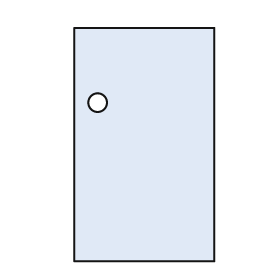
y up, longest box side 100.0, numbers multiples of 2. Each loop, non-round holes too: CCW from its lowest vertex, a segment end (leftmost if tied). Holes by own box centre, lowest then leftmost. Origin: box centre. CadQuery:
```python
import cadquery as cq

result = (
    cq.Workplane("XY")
    .moveTo(-30.0, -50.0)
    .lineTo(30.0, -50.0)
    .lineTo(30.0, 50.0)
    .lineTo(-30.0, 50.0)
    .close()
    .moveTo(-20.0, 18.0)
    .circle(4.0)
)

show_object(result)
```